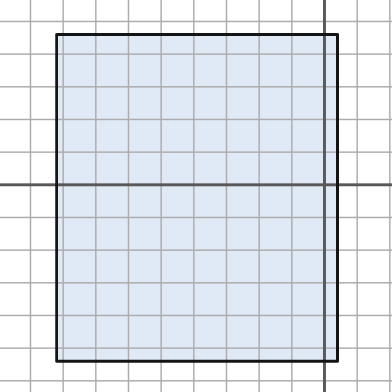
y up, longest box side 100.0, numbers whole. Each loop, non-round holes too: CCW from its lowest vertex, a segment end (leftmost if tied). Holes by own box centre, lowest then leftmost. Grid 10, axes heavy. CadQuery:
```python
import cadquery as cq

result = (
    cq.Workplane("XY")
    .moveTo(-82.0, -54.0)
    .lineTo(4.0, -54.0)
    .lineTo(4.0, 46.0)
    .lineTo(-82.0, 46.0)
    .close()
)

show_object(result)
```